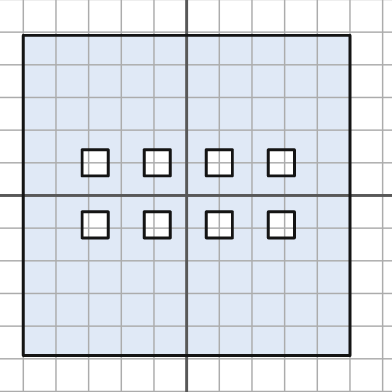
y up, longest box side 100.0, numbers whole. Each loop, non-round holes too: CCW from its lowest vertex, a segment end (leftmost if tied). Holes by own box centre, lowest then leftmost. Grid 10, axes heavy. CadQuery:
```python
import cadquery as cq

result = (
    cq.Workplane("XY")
    .moveTo(-50.0, -49.0)
    .lineTo(50.0, -49.0)
    .lineTo(50.0, 49.0)
    .lineTo(-50.0, 49.0)
    .close()
    .moveTo(-32.0, -13.0)
    .lineTo(-24.0, -13.0)
    .lineTo(-24.0, -5.0)
    .lineTo(-32.0, -5.0)
    .close()
    .moveTo(-13.0, -13.0)
    .lineTo(-5.0, -13.0)
    .lineTo(-5.0, -5.0)
    .lineTo(-13.0, -5.0)
    .close()
    .moveTo(6.0, -13.0)
    .lineTo(14.0, -13.0)
    .lineTo(14.0, -5.0)
    .lineTo(6.0, -5.0)
    .close()
    .moveTo(25.0, -13.0)
    .lineTo(33.0, -13.0)
    .lineTo(33.0, -5.0)
    .lineTo(25.0, -5.0)
    .close()
    .moveTo(-32.0, 6.0)
    .lineTo(-24.0, 6.0)
    .lineTo(-24.0, 14.0)
    .lineTo(-32.0, 14.0)
    .close()
    .moveTo(-13.0, 6.0)
    .lineTo(-5.0, 6.0)
    .lineTo(-5.0, 14.0)
    .lineTo(-13.0, 14.0)
    .close()
    .moveTo(6.0, 6.0)
    .lineTo(14.0, 6.0)
    .lineTo(14.0, 14.0)
    .lineTo(6.0, 14.0)
    .close()
    .moveTo(25.0, 6.0)
    .lineTo(33.0, 6.0)
    .lineTo(33.0, 14.0)
    .lineTo(25.0, 14.0)
    .close()
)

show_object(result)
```